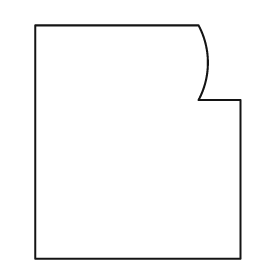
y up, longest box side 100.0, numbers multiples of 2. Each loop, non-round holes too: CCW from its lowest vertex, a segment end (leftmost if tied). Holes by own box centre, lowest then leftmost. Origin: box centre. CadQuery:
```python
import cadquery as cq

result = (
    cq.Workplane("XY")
    .moveTo(-44.0, -50.0)
    .lineTo(44.0, -50.0)
    .lineTo(44.0, 18.0)
    .lineTo(26.0, 18.0)
    .threePointArc((30.0, 34.0), (26.0, 50.0))
    .lineTo(-44.0, 50.0)
    .close()
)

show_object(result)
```